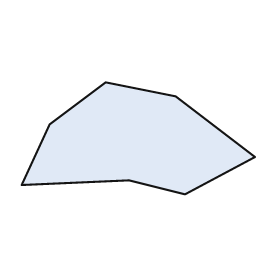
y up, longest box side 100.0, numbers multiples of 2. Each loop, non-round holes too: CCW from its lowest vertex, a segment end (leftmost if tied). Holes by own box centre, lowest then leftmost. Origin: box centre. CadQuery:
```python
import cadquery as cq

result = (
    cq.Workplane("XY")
    .moveTo(20.0, -24.0)
    .lineTo(50.0, -8.0)
    .lineTo(16.0, 18.0)
    .lineTo(-14.0, 24.0)
    .lineTo(-38.0, 6.0)
    .lineTo(-50.0, -20.0)
    .lineTo(-4.0, -18.0)
    .close()
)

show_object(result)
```